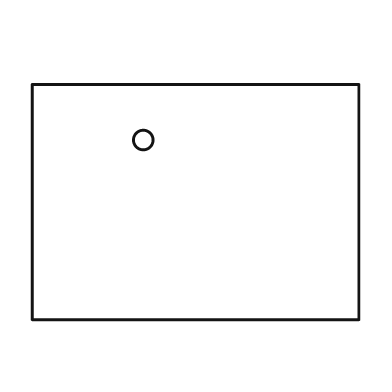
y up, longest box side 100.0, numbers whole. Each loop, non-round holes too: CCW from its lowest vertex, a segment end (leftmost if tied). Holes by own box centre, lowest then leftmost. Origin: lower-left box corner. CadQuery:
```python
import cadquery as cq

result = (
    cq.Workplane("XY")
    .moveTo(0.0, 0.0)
    .lineTo(100.0, 0.0)
    .lineTo(100.0, 72.0)
    .lineTo(0.0, 72.0)
    .close()
    .moveTo(34.0, 55.0)
    .circle(3.0)
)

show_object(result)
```